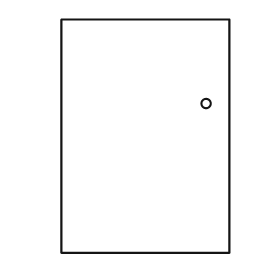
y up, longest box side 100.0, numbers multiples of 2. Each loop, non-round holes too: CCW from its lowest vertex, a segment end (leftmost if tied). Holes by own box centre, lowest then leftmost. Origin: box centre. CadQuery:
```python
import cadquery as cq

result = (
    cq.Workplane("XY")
    .moveTo(-36.0, -50.0)
    .lineTo(36.0, -50.0)
    .lineTo(36.0, 50.0)
    .lineTo(-36.0, 50.0)
    .close()
    .moveTo(26.0, 14.0)
    .circle(2.0)
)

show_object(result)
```